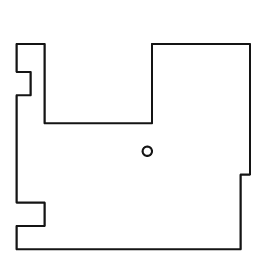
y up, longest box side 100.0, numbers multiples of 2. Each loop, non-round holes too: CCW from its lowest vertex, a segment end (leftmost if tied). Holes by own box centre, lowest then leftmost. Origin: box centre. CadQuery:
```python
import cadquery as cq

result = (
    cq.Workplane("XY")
    .moveTo(-50.0, -44.0)
    .lineTo(46.0, -44.0)
    .lineTo(46.0, -12.0)
    .lineTo(50.0, -12.0)
    .lineTo(50.0, 44.0)
    .lineTo(8.0, 44.0)
    .lineTo(8.0, 10.0)
    .lineTo(-38.0, 10.0)
    .lineTo(-38.0, 44.0)
    .lineTo(-50.0, 44.0)
    .lineTo(-50.0, 32.0)
    .lineTo(-44.0, 32.0)
    .lineTo(-44.0, 22.0)
    .lineTo(-50.0, 22.0)
    .lineTo(-50.0, -24.0)
    .lineTo(-38.0, -24.0)
    .lineTo(-38.0, -34.0)
    .lineTo(-50.0, -34.0)
    .close()
    .moveTo(6.0, -2.0)
    .circle(2.0)
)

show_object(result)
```